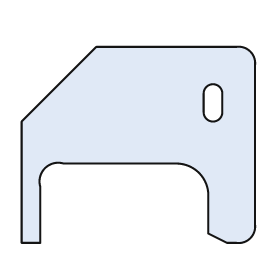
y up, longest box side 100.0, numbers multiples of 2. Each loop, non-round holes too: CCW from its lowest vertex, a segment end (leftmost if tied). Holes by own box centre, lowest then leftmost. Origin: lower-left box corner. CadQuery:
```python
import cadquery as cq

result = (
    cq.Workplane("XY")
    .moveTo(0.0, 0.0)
    .lineTo(8.0, 0.0)
    .lineTo(8.0, 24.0)
    .threePointArc((10.0, 32.0), (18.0, 34.0))
    .lineTo(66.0, 34.0)
    .threePointArc((76.0, 30.0), (80.0, 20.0))
    .lineTo(80.0, 4.0)
    .lineTo(88.0, 0.0)
    .lineTo(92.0, 0.0)
    .threePointArc((98.0, 2.0), (100.0, 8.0))
    .lineTo(100.0, 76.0)
    .threePointArc((98.0, 82.0), (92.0, 84.0))
    .lineTo(32.0, 84.0)
    .lineTo(0.0, 52.0)
    .close()
    .moveTo(78.0, 56.0)
    .threePointArc((82.0, 52.0), (86.0, 56.0))
    .lineTo(86.0, 64.0)
    .threePointArc((82.0, 68.0), (78.0, 64.0))
    .close()
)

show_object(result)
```